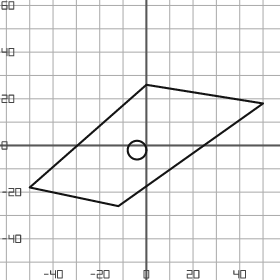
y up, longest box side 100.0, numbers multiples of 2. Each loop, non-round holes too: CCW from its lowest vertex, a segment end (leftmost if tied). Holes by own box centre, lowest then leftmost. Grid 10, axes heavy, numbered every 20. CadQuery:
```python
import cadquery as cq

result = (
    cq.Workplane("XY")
    .moveTo(-12.0, -26.0)
    .lineTo(50.0, 18.0)
    .lineTo(0.0, 26.0)
    .lineTo(-50.0, -18.0)
    .close()
    .moveTo(-4.0, -2.0)
    .circle(4.0)
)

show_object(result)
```